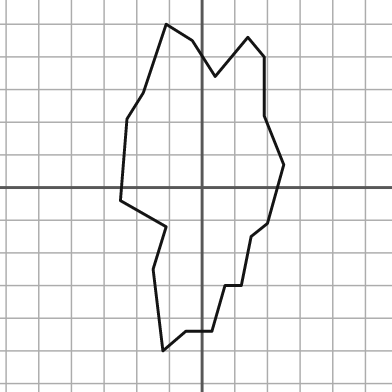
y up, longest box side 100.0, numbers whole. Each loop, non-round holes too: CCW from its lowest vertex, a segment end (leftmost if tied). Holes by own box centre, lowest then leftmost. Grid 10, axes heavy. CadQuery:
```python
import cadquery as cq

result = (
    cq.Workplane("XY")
    .moveTo(-12.0, -50.0)
    .lineTo(-5.0, -44.0)
    .lineTo(3.0, -44.0)
    .lineTo(7.0, -30.0)
    .lineTo(12.0, -30.0)
    .lineTo(15.0, -15.0)
    .lineTo(20.0, -11.0)
    .lineTo(25.0, 7.0)
    .lineTo(19.0, 22.0)
    .lineTo(19.0, 40.0)
    .lineTo(14.0, 46.0)
    .lineTo(4.0, 34.0)
    .lineTo(-3.0, 45.0)
    .lineTo(-11.0, 50.0)
    .lineTo(-18.0, 29.0)
    .lineTo(-23.0, 21.0)
    .lineTo(-25.0, -4.0)
    .lineTo(-11.0, -12.0)
    .lineTo(-15.0, -25.0)
    .close()
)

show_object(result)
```